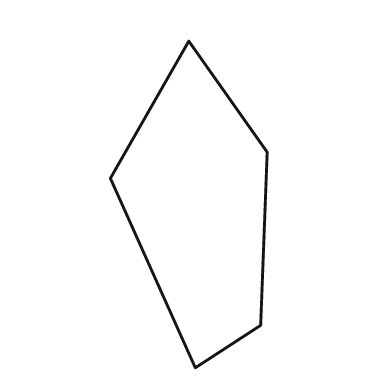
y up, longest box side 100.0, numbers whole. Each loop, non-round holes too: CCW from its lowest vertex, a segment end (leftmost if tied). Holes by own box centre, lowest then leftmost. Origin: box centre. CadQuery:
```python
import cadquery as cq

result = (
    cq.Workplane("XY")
    .moveTo(2.0, -50.0)
    .lineTo(22.0, -37.0)
    .lineTo(24.0, 16.0)
    .lineTo(0.0, 50.0)
    .lineTo(-24.0, 8.0)
    .close()
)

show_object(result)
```